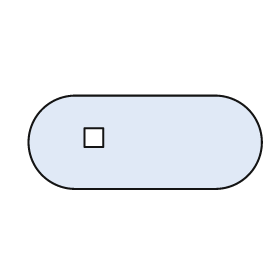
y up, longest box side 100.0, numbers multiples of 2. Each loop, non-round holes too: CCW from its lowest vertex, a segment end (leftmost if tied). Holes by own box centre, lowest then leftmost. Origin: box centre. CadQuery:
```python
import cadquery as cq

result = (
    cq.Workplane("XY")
    .moveTo(-30.0, -20.0)
    .lineTo(30.0, -20.0)
    .threePointArc((50.0, 0.0), (30.0, 20.0))
    .lineTo(-30.0, 20.0)
    .threePointArc((-50.0, 0.0), (-30.0, -20.0))
    .close()
    .moveTo(-26.0, -2.0)
    .lineTo(-18.0, -2.0)
    .lineTo(-18.0, 6.0)
    .lineTo(-26.0, 6.0)
    .close()
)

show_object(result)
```